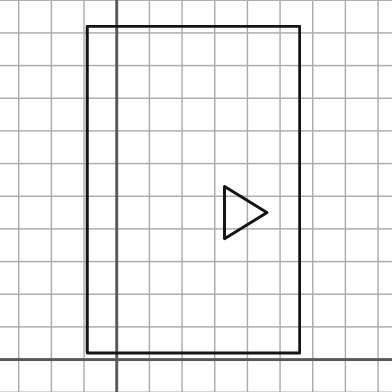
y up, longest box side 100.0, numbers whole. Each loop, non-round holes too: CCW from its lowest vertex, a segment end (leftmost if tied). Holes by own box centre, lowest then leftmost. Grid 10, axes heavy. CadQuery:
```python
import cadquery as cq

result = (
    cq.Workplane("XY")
    .moveTo(-9.0, 2.0)
    .lineTo(56.0, 2.0)
    .lineTo(56.0, 102.0)
    .lineTo(-9.0, 102.0)
    .close()
    .moveTo(33.0, 37.0)
    .lineTo(46.0, 45.0)
    .lineTo(33.0, 53.0)
    .close()
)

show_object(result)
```